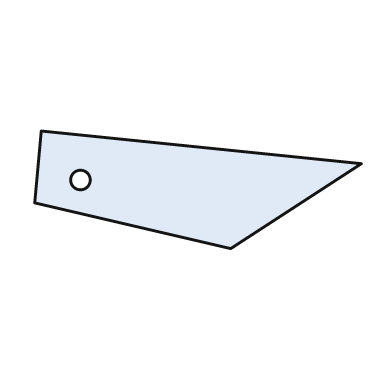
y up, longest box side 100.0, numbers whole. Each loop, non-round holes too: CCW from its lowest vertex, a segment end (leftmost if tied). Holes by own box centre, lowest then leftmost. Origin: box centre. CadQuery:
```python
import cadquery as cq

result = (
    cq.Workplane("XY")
    .moveTo(10.0, -18.0)
    .lineTo(50.0, 8.0)
    .lineTo(-48.0, 18.0)
    .lineTo(-50.0, -4.0)
    .close()
    .moveTo(-36.0, 3.0)
    .circle(3.0)
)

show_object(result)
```